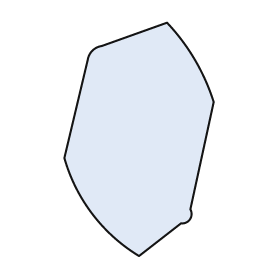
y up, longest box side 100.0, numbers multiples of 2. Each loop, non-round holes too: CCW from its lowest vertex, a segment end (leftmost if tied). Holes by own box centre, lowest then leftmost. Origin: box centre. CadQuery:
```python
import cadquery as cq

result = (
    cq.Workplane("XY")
    .moveTo(0.0, -50.0)
    .lineTo(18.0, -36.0)
    .threePointArc((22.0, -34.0), (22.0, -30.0))
    .lineTo(32.0, 16.0)
    .threePointArc((24.0, 34.0), (12.0, 50.0))
    .lineTo(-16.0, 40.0)
    .threePointArc((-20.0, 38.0), (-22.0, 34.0))
    .lineTo(-32.0, -8.0)
    .threePointArc((-20.0, -32.0), (0.0, -50.0))
    .close()
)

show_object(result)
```